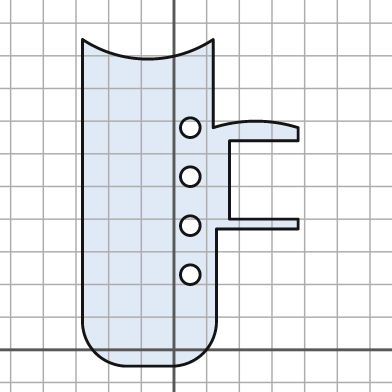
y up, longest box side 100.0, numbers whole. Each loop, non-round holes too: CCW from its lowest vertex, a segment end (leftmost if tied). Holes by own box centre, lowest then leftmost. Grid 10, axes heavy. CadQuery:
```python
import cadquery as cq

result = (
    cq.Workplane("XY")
    .moveTo(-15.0, -5.0)
    .lineTo(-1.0, -5.0)
    .threePointArc((9.0, -1.0), (13.0, 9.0))
    .lineTo(13.0, 37.0)
    .lineTo(38.0, 37.0)
    .lineTo(38.0, 40.0)
    .lineTo(17.0, 40.0)
    .lineTo(17.0, 64.0)
    .lineTo(38.0, 64.0)
    .lineTo(38.0, 68.0)
    .threePointArc((25.0, 70.0), (12.0, 68.0))
    .lineTo(12.0, 95.0)
    .threePointArc((-8.0, 89.0), (-28.0, 95.0))
    .lineTo(-28.0, 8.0)
    .threePointArc((-24.0, -1.0), (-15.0, -5.0))
    .close()
    .moveTo(5.0, 23.0)
    .circle(3.0)
    .moveTo(5.0, 38.0)
    .circle(3.0)
    .moveTo(5.0, 53.0)
    .circle(3.0)
    .moveTo(5.0, 68.0)
    .circle(3.0)
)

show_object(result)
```